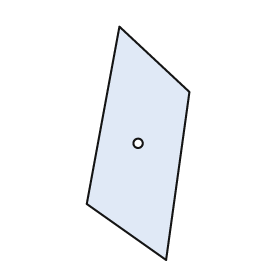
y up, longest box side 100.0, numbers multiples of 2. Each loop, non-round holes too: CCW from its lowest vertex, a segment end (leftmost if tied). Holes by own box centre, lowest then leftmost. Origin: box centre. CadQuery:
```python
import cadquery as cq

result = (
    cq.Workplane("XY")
    .moveTo(12.0, -50.0)
    .lineTo(22.0, 22.0)
    .lineTo(-8.0, 50.0)
    .lineTo(-22.0, -26.0)
    .close()
    .moveTo(0.0, 0.0)
    .circle(2.0)
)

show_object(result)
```